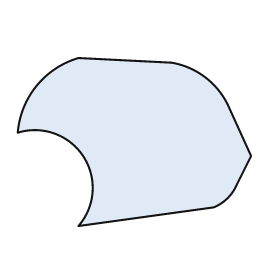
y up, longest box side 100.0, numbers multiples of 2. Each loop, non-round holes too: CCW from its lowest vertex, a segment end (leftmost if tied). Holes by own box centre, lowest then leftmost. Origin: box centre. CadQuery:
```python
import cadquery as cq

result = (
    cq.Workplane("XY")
    .moveTo(-24.0, -36.0)
    .lineTo(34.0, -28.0)
    .threePointArc((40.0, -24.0), (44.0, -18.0))
    .lineTo(50.0, -6.0)
    .lineTo(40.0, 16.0)
    .threePointArc((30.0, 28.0), (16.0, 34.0))
    .lineTo(-24.0, 36.0)
    .threePointArc((-42.0, 24.0), (-50.0, 4.0))
    .threePointArc((-22.0, -6.0), (-24.0, -36.0))
    .close()
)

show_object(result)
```